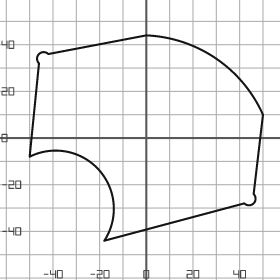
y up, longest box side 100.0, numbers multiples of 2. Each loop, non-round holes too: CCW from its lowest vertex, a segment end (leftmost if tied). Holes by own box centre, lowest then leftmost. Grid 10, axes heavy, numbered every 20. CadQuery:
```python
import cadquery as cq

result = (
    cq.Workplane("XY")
    .moveTo(-18.0, -44.0)
    .lineTo(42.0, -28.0)
    .threePointArc((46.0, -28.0), (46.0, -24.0))
    .lineTo(50.0, 10.0)
    .threePointArc((30.0, 34.0), (0.0, 44.0))
    .lineTo(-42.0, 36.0)
    .threePointArc((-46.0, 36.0), (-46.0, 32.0))
    .lineTo(-50.0, -8.0)
    .threePointArc((-20.0, -14.0), (-18.0, -44.0))
    .close()
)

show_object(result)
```